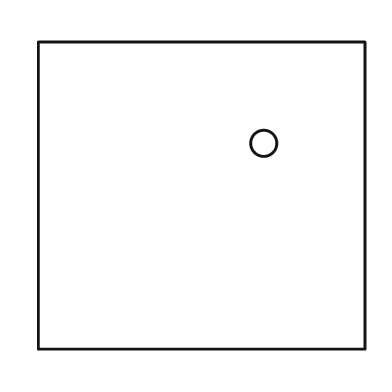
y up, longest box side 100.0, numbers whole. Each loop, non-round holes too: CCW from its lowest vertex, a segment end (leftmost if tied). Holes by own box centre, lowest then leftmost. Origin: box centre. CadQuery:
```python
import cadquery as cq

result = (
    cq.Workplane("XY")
    .moveTo(-50.0, -47.0)
    .lineTo(50.0, -47.0)
    .lineTo(50.0, 47.0)
    .lineTo(-50.0, 47.0)
    .close()
    .moveTo(19.0, 16.0)
    .circle(4.0)
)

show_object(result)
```